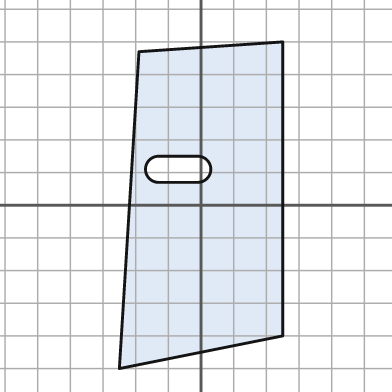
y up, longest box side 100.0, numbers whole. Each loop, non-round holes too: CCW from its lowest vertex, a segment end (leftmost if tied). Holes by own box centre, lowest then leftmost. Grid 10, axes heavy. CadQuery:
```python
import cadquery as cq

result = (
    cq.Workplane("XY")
    .moveTo(-25.0, -50.0)
    .lineTo(25.0, -40.0)
    .lineTo(25.0, 50.0)
    .lineTo(-19.0, 47.0)
    .close()
    .moveTo(-13.0, 7.0)
    .lineTo(-1.0, 7.0)
    .threePointArc((3.0, 11.0), (-1.0, 15.0))
    .lineTo(-13.0, 15.0)
    .threePointArc((-17.0, 11.0), (-13.0, 7.0))
    .close()
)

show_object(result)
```